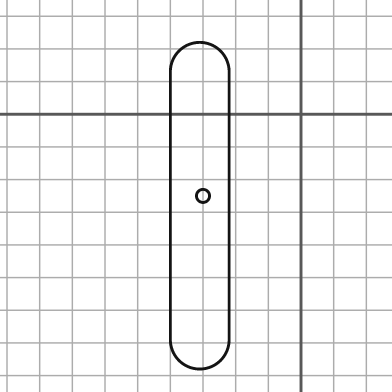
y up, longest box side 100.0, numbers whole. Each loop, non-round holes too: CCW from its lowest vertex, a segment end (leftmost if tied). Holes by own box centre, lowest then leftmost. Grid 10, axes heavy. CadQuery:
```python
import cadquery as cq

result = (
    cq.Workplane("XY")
    .moveTo(-40.0, -69.0)
    .threePointArc((-31.0, -78.0), (-22.0, -69.0))
    .lineTo(-22.0, 13.0)
    .threePointArc((-31.0, 22.0), (-40.0, 13.0))
    .close()
    .moveTo(-30.0, -25.0)
    .circle(2.0)
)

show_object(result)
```